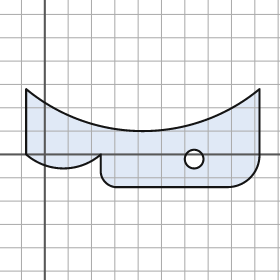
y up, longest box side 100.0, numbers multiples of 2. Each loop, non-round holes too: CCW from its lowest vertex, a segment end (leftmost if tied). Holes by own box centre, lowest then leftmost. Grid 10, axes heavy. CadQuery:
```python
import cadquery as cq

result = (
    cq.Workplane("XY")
    .moveTo(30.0, -14.0)
    .lineTo(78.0, -14.0)
    .threePointArc((88.0, -10.0), (92.0, 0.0))
    .lineTo(92.0, 28.0)
    .threePointArc((42.0, 10.0), (-8.0, 28.0))
    .lineTo(-8.0, 0.0)
    .threePointArc((8.0, -6.0), (24.0, 0.0))
    .lineTo(24.0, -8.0)
    .threePointArc((26.0, -12.0), (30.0, -14.0))
    .close()
    .moveTo(64.0, -2.0)
    .circle(4.0)
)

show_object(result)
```